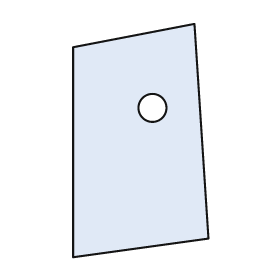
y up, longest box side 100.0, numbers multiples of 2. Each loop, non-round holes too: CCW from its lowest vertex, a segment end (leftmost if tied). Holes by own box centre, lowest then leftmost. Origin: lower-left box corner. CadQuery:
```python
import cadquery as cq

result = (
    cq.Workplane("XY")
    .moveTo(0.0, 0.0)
    .lineTo(58.0, 8.0)
    .lineTo(52.0, 100.0)
    .lineTo(0.0, 90.0)
    .close()
    .moveTo(34.0, 64.0)
    .circle(6.0)
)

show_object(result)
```